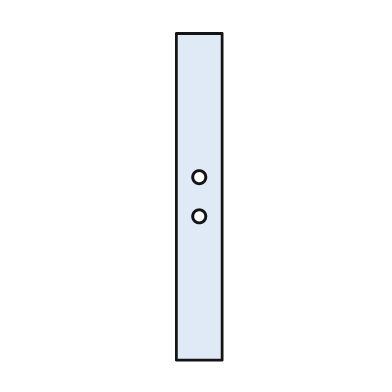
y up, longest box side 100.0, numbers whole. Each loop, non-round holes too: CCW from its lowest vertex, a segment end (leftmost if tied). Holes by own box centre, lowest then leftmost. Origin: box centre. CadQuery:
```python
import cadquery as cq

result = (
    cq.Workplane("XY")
    .moveTo(-7.0, -50.0)
    .lineTo(7.0, -50.0)
    .lineTo(7.0, 50.0)
    .lineTo(-7.0, 50.0)
    .close()
    .moveTo(0.0, -6.0)
    .circle(2.0)
    .moveTo(0.0, 6.0)
    .circle(2.0)
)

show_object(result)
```